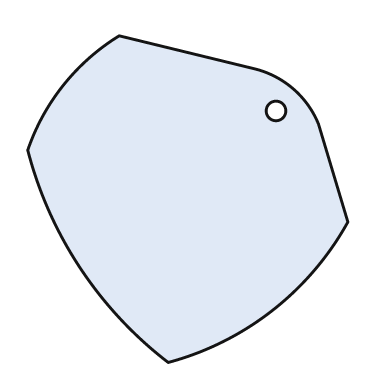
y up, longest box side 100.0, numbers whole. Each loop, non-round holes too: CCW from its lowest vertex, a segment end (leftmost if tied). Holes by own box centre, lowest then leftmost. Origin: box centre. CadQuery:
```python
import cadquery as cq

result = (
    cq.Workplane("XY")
    .moveTo(-6.0, -50.0)
    .threePointArc((26.0, -34.0), (49.0, -7.0))
    .lineTo(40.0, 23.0)
    .threePointArc((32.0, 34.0), (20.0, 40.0))
    .lineTo(-21.0, 50.0)
    .threePointArc((-38.0, 35.0), (-49.0, 15.0))
    .threePointArc((-33.0, -21.0), (-6.0, -50.0))
    .close()
    .moveTo(27.0, 27.0)
    .circle(3.0)
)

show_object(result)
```